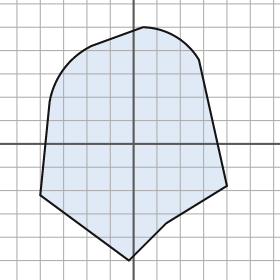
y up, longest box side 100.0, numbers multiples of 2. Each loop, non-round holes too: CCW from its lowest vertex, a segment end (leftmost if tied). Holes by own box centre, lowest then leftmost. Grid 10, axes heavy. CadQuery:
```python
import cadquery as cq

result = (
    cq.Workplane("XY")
    .moveTo(-2.0, -50.0)
    .lineTo(14.0, -34.0)
    .lineTo(40.0, -18.0)
    .lineTo(28.0, 36.0)
    .threePointArc((18.0, 46.0), (4.0, 50.0))
    .lineTo(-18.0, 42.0)
    .threePointArc((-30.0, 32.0), (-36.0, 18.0))
    .lineTo(-40.0, -22.0)
    .close()
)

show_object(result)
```